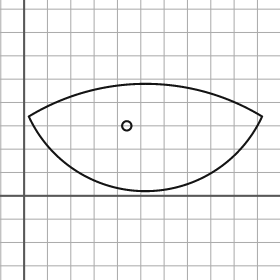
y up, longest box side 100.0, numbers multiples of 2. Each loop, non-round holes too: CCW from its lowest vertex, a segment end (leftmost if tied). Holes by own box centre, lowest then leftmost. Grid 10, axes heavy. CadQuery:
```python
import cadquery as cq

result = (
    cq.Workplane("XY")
    .moveTo(2.0, 34.0)
    .threePointArc((52.0, 2.0), (102.0, 34.0))
    .threePointArc((52.0, 48.0), (2.0, 34.0))
    .close()
    .moveTo(44.0, 30.0)
    .circle(2.0)
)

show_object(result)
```